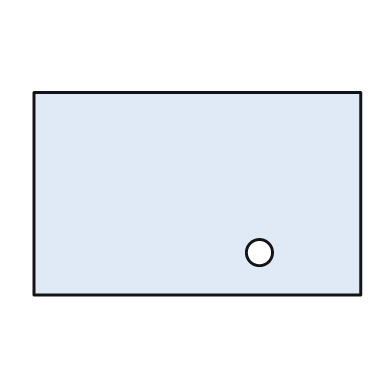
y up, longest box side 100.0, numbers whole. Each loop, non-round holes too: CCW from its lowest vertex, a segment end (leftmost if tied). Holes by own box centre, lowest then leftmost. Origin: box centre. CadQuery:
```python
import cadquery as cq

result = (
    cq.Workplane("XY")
    .moveTo(-50.0, -31.0)
    .lineTo(50.0, -31.0)
    .lineTo(50.0, 31.0)
    .lineTo(-50.0, 31.0)
    .close()
    .moveTo(19.0, -18.0)
    .circle(4.0)
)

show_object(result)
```